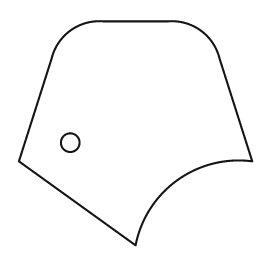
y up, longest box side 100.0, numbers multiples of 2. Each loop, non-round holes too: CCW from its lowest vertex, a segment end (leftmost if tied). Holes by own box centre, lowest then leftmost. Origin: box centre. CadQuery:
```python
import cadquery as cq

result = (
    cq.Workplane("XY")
    .moveTo(0.0, -48.0)
    .threePointArc((18.0, -20.0), (50.0, -12.0))
    .lineTo(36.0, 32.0)
    .threePointArc((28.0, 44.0), (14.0, 48.0))
    .lineTo(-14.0, 48.0)
    .threePointArc((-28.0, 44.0), (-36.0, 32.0))
    .lineTo(-50.0, -12.0)
    .close()
    .moveTo(-28.0, -4.0)
    .circle(4.0)
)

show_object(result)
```